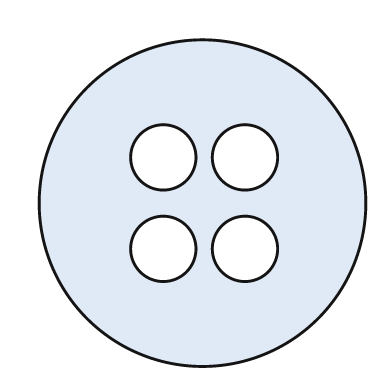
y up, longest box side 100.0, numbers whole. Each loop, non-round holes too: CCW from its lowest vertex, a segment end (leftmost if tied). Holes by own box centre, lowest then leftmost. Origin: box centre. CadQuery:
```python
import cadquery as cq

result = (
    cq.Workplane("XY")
    .moveTo(0.0, 0.0)
    .circle(50.0)
    .moveTo(-12.0, -14.0)
    .circle(10.0)
    .moveTo(13.0, -14.0)
    .circle(10.0)
    .moveTo(-12.0, 14.0)
    .circle(10.0)
    .moveTo(13.0, 14.0)
    .circle(10.0)
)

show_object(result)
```